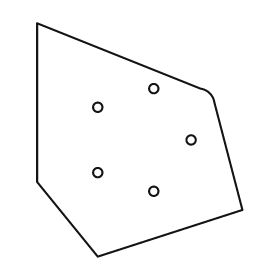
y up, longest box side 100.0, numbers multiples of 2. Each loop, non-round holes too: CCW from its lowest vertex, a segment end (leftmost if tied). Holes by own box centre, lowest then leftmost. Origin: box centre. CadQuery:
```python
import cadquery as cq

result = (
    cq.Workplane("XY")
    .moveTo(-18.0, -50.0)
    .lineTo(44.0, -30.0)
    .lineTo(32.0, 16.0)
    .threePointArc((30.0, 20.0), (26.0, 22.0))
    .lineTo(-44.0, 50.0)
    .lineTo(-44.0, -18.0)
    .close()
    .moveTo(6.0, -22.0)
    .circle(2.0)
    .moveTo(-18.0, -14.0)
    .circle(2.0)
    .moveTo(22.0, 0.0)
    .circle(2.0)
    .moveTo(-18.0, 14.0)
    .circle(2.0)
    .moveTo(6.0, 22.0)
    .circle(2.0)
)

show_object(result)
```